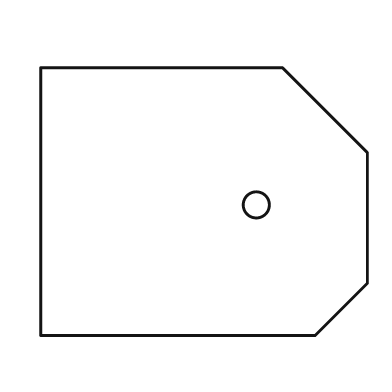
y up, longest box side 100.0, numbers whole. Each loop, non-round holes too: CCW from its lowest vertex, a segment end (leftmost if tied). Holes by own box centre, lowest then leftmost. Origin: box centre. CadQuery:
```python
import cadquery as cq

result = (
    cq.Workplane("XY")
    .moveTo(-50.0, -41.0)
    .lineTo(34.0, -41.0)
    .lineTo(50.0, -25.0)
    .lineTo(50.0, 15.0)
    .lineTo(24.0, 41.0)
    .lineTo(-50.0, 41.0)
    .close()
    .moveTo(16.0, -1.0)
    .circle(4.0)
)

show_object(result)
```